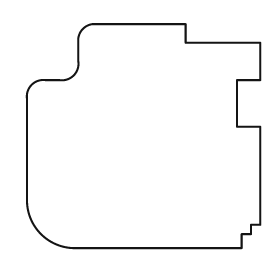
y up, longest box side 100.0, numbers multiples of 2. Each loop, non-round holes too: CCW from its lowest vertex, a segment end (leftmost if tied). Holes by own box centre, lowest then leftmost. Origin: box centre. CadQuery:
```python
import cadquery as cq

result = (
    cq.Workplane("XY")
    .moveTo(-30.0, -48.0)
    .lineTo(42.0, -48.0)
    .lineTo(42.0, -42.0)
    .lineTo(46.0, -42.0)
    .lineTo(46.0, -38.0)
    .lineTo(50.0, -38.0)
    .lineTo(50.0, 4.0)
    .lineTo(40.0, 4.0)
    .lineTo(40.0, 24.0)
    .lineTo(50.0, 24.0)
    .lineTo(50.0, 40.0)
    .lineTo(18.0, 40.0)
    .lineTo(18.0, 48.0)
    .lineTo(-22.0, 48.0)
    .threePointArc((-26.0, 46.0), (-28.0, 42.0))
    .lineTo(-28.0, 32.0)
    .threePointArc((-30.0, 26.0), (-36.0, 24.0))
    .lineTo(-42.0, 24.0)
    .threePointArc((-48.0, 22.0), (-50.0, 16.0))
    .lineTo(-50.0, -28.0)
    .threePointArc((-44.0, -42.0), (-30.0, -48.0))
    .close()
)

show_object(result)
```